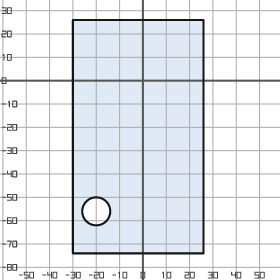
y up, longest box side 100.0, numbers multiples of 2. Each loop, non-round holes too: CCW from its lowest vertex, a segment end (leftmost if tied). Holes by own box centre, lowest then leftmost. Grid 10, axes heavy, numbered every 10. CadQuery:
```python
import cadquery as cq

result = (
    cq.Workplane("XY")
    .moveTo(-30.0, -74.0)
    .lineTo(26.0, -74.0)
    .lineTo(26.0, 26.0)
    .lineTo(-30.0, 26.0)
    .close()
    .moveTo(-20.0, -56.0)
    .circle(6.0)
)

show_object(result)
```